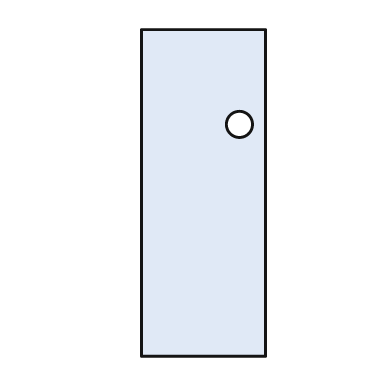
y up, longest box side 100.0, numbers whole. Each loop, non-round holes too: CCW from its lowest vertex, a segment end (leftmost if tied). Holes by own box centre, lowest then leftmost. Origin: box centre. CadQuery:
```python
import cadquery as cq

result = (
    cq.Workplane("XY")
    .moveTo(-19.0, -50.0)
    .lineTo(19.0, -50.0)
    .lineTo(19.0, 50.0)
    .lineTo(-19.0, 50.0)
    .close()
    .moveTo(11.0, 21.0)
    .circle(4.0)
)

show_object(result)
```